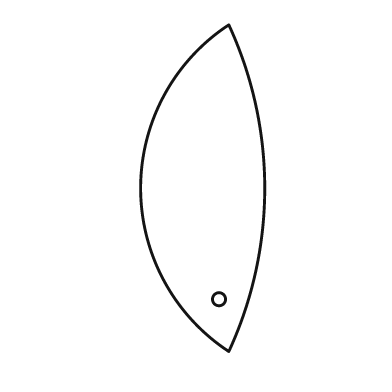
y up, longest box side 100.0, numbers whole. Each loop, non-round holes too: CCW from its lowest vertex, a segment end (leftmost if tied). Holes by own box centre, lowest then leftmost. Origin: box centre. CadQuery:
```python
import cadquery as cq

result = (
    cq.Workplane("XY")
    .moveTo(8.0, -50.0)
    .threePointArc((19.0, 0.0), (8.0, 50.0))
    .threePointArc((-19.0, 0.0), (8.0, -50.0))
    .close()
    .moveTo(5.0, -34.0)
    .circle(2.0)
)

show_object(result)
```